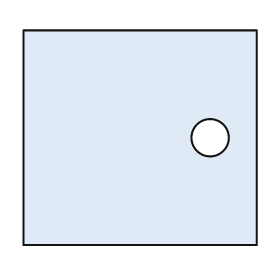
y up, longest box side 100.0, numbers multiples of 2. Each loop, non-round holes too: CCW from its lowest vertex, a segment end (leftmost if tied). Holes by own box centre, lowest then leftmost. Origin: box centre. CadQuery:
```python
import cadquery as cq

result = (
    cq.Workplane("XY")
    .moveTo(-50.0, -46.0)
    .lineTo(50.0, -46.0)
    .lineTo(50.0, 46.0)
    .lineTo(-50.0, 46.0)
    .close()
    .moveTo(30.0, 0.0)
    .circle(8.0)
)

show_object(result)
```